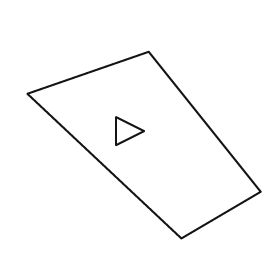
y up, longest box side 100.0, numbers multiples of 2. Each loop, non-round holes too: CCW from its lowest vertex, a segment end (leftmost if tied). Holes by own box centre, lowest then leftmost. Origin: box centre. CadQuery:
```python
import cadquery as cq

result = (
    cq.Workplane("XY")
    .moveTo(16.0, -40.0)
    .lineTo(50.0, -20.0)
    .lineTo(2.0, 40.0)
    .lineTo(-50.0, 22.0)
    .close()
    .moveTo(-12.0, 0.0)
    .lineTo(0.0, 6.0)
    .lineTo(-12.0, 12.0)
    .close()
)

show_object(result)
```